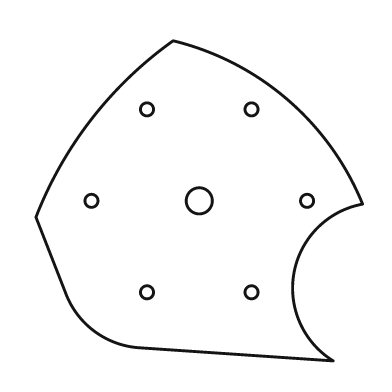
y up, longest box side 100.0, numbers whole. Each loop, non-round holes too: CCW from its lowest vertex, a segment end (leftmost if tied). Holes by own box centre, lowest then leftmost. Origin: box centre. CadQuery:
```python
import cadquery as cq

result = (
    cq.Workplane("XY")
    .moveTo(41.0, -49.0)
    .threePointArc((29.0, -22.0), (50.0, -1.0))
    .threePointArc((27.0, 31.0), (-8.0, 49.0))
    .threePointArc((-33.0, 25.0), (-50.0, -5.0))
    .lineTo(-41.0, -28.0)
    .threePointArc((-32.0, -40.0), (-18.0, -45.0))
    .close()
    .moveTo(-16.0, -28.0)
    .circle(2.0)
    .moveTo(16.0, -28.0)
    .circle(2.0)
    .moveTo(-33.0, 0.0)
    .circle(2.0)
    .moveTo(0.0, 0.0)
    .circle(4.0)
    .moveTo(33.0, 0.0)
    .circle(2.0)
    .moveTo(-16.0, 28.0)
    .circle(2.0)
    .moveTo(16.0, 28.0)
    .circle(2.0)
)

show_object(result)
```